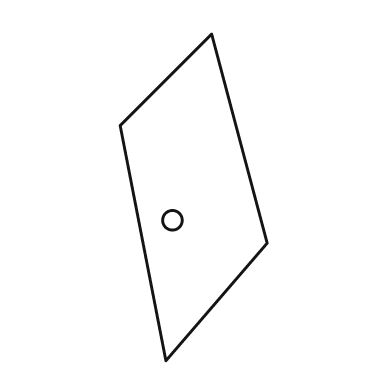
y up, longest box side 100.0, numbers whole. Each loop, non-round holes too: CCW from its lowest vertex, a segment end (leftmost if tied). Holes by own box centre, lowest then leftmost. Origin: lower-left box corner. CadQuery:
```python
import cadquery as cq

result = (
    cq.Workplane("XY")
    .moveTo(14.0, 0.0)
    .lineTo(45.0, 36.0)
    .lineTo(28.0, 100.0)
    .lineTo(0.0, 72.0)
    .close()
    .moveTo(16.0, 43.0)
    .circle(3.0)
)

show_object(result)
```